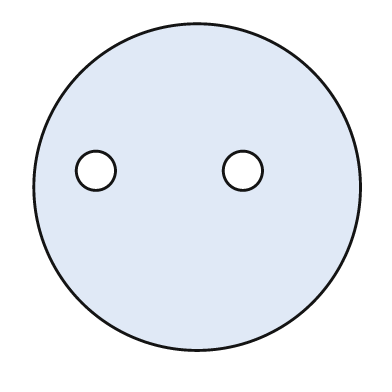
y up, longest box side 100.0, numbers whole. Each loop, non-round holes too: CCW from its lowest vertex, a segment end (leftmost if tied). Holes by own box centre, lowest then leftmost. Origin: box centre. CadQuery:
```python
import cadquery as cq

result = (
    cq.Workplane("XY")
    .moveTo(0.0, 0.0)
    .circle(50.0)
    .moveTo(-31.0, 5.0)
    .circle(6.0)
    .moveTo(14.0, 5.0)
    .circle(6.0)
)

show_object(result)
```